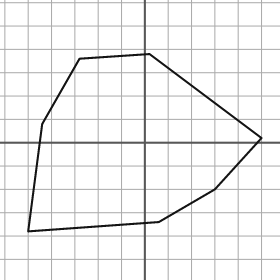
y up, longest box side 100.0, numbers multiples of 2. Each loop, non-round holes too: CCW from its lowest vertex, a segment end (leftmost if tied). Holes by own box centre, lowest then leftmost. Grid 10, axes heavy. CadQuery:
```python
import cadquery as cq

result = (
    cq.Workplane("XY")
    .moveTo(-50.0, -38.0)
    .lineTo(6.0, -34.0)
    .lineTo(30.0, -20.0)
    .lineTo(50.0, 2.0)
    .lineTo(2.0, 38.0)
    .lineTo(-28.0, 36.0)
    .lineTo(-44.0, 8.0)
    .close()
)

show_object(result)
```